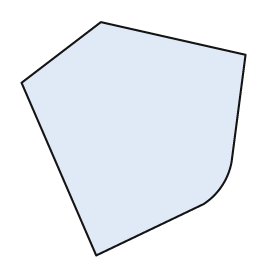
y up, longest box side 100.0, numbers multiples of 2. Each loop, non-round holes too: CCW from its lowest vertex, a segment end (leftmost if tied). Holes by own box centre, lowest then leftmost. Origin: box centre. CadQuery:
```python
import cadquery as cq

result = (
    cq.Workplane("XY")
    .moveTo(-16.0, -50.0)
    .lineTo(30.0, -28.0)
    .threePointArc((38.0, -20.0), (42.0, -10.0))
    .lineTo(48.0, 36.0)
    .lineTo(-14.0, 50.0)
    .lineTo(-48.0, 24.0)
    .close()
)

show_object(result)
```